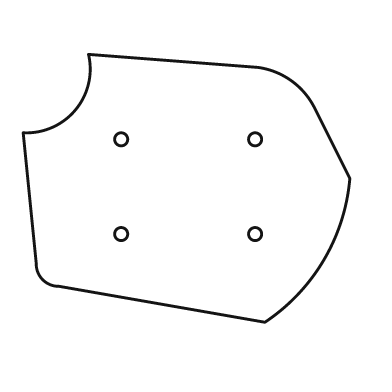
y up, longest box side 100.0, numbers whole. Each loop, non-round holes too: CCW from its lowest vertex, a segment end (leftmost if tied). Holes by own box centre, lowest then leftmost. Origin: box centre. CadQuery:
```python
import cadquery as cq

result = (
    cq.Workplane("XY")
    .moveTo(24.0, -41.0)
    .threePointArc((42.0, -22.0), (50.0, 3.0))
    .lineTo(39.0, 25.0)
    .threePointArc((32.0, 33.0), (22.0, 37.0))
    .lineTo(-30.0, 41.0)
    .threePointArc((-34.0, 24.0), (-50.0, 17.0))
    .lineTo(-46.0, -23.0)
    .threePointArc((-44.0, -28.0), (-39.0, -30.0))
    .close()
    .moveTo(-20.0, -14.0)
    .circle(2.0)
    .moveTo(21.0, -14.0)
    .circle(2.0)
    .moveTo(-20.0, 15.0)
    .circle(2.0)
    .moveTo(21.0, 15.0)
    .circle(2.0)
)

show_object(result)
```